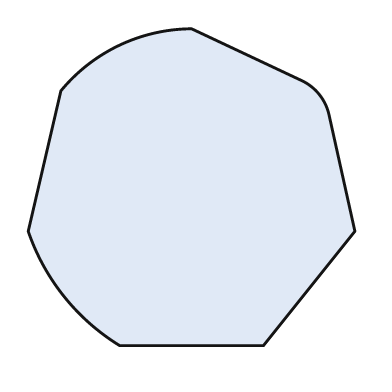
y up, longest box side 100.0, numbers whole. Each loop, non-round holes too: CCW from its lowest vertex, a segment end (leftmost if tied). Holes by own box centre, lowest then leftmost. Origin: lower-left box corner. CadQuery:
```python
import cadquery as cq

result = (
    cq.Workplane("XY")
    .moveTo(28.0, 0.0)
    .lineTo(72.0, 0.0)
    .lineTo(100.0, 35.0)
    .lineTo(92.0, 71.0)
    .threePointArc((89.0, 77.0), (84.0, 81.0))
    .lineTo(50.0, 97.0)
    .threePointArc((28.0, 92.0), (10.0, 78.0))
    .lineTo(0.0, 35.0)
    .threePointArc((11.0, 15.0), (28.0, 0.0))
    .close()
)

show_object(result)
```